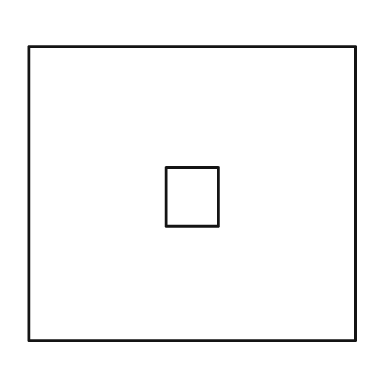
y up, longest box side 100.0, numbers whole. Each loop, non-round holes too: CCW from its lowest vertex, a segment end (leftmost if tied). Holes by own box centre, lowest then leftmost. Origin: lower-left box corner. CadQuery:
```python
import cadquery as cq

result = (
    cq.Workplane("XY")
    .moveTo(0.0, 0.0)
    .lineTo(100.0, 0.0)
    .lineTo(100.0, 90.0)
    .lineTo(0.0, 90.0)
    .close()
    .moveTo(42.0, 35.0)
    .lineTo(58.0, 35.0)
    .lineTo(58.0, 53.0)
    .lineTo(42.0, 53.0)
    .close()
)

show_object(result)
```